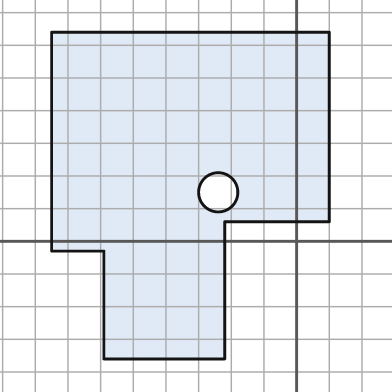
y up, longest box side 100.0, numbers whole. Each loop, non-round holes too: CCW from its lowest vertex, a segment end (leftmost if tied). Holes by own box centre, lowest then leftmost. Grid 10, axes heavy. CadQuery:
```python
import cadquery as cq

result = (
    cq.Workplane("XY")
    .moveTo(-59.0, -36.0)
    .lineTo(-22.0, -36.0)
    .lineTo(-22.0, 6.0)
    .lineTo(10.0, 6.0)
    .lineTo(10.0, 64.0)
    .lineTo(-75.0, 64.0)
    .lineTo(-75.0, -3.0)
    .lineTo(-59.0, -3.0)
    .close()
    .moveTo(-24.0, 15.0)
    .circle(6.0)
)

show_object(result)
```